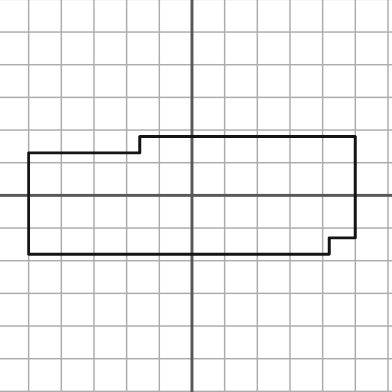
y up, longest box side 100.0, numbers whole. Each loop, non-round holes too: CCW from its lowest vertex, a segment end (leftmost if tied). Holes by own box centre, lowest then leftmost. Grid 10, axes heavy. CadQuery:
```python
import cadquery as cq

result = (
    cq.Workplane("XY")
    .moveTo(-50.0, -18.0)
    .lineTo(42.0, -18.0)
    .lineTo(42.0, -13.0)
    .lineTo(50.0, -13.0)
    .lineTo(50.0, 18.0)
    .lineTo(-16.0, 18.0)
    .lineTo(-16.0, 13.0)
    .lineTo(-50.0, 13.0)
    .close()
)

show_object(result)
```